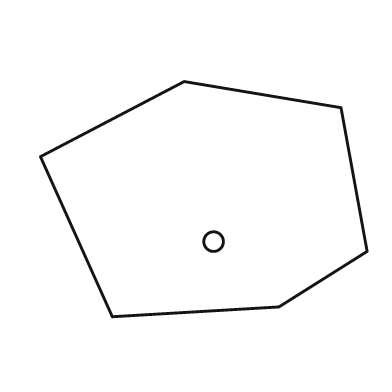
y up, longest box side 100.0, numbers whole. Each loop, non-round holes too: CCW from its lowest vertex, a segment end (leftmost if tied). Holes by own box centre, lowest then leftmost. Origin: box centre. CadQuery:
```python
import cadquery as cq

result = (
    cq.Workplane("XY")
    .moveTo(-28.0, -36.0)
    .lineTo(23.0, -33.0)
    .lineTo(50.0, -16.0)
    .lineTo(42.0, 28.0)
    .lineTo(-6.0, 36.0)
    .lineTo(-50.0, 13.0)
    .close()
    .moveTo(3.0, -13.0)
    .circle(3.0)
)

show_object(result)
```